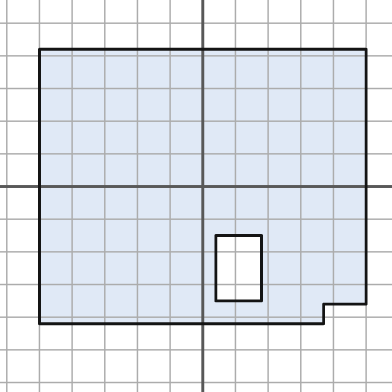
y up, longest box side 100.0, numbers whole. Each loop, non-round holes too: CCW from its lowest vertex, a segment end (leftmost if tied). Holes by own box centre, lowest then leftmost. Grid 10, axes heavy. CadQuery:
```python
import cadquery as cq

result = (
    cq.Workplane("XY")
    .moveTo(-50.0, -42.0)
    .lineTo(37.0, -42.0)
    .lineTo(37.0, -36.0)
    .lineTo(50.0, -36.0)
    .lineTo(50.0, 42.0)
    .lineTo(-50.0, 42.0)
    .close()
    .moveTo(4.0, -35.0)
    .lineTo(18.0, -35.0)
    .lineTo(18.0, -15.0)
    .lineTo(4.0, -15.0)
    .close()
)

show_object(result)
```